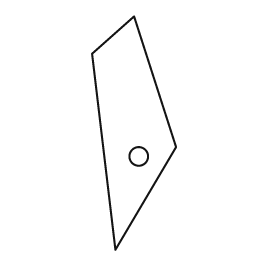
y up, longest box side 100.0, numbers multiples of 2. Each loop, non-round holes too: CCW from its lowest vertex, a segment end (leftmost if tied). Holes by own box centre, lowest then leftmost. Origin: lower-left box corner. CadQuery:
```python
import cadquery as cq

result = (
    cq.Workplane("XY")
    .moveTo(10.0, 0.0)
    .lineTo(36.0, 44.0)
    .lineTo(18.0, 100.0)
    .lineTo(0.0, 84.0)
    .close()
    .moveTo(20.0, 40.0)
    .circle(4.0)
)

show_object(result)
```